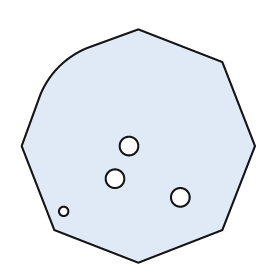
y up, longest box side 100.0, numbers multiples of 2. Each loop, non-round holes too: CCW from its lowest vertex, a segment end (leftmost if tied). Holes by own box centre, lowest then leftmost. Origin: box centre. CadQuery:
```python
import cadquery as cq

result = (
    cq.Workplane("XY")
    .moveTo(0.0, -50.0)
    .lineTo(36.0, -36.0)
    .lineTo(50.0, 0.0)
    .lineTo(36.0, 36.0)
    .lineTo(0.0, 50.0)
    .lineTo(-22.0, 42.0)
    .threePointArc((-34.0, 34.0), (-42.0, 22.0))
    .lineTo(-50.0, 0.0)
    .lineTo(-36.0, -36.0)
    .close()
    .moveTo(-32.0, -28.0)
    .circle(2.0)
    .moveTo(18.0, -22.0)
    .circle(4.0)
    .moveTo(-10.0, -14.0)
    .circle(4.0)
    .moveTo(-4.0, 0.0)
    .circle(4.0)
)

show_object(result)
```